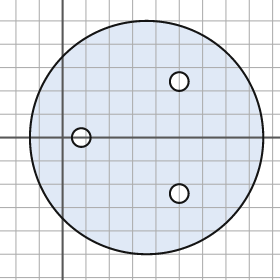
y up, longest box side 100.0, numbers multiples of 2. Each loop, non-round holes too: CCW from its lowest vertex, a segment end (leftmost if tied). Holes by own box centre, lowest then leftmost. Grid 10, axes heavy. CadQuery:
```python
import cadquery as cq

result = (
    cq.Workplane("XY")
    .moveTo(36.0, 0.0)
    .circle(50.0)
    .moveTo(50.0, -24.0)
    .circle(4.0)
    .moveTo(8.0, 0.0)
    .circle(4.0)
    .moveTo(50.0, 24.0)
    .circle(4.0)
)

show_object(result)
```